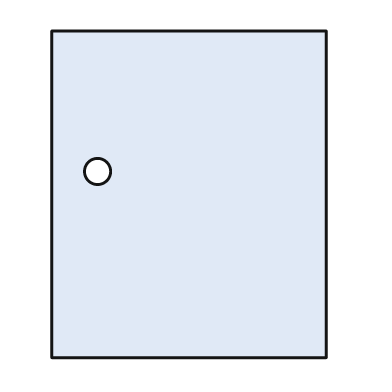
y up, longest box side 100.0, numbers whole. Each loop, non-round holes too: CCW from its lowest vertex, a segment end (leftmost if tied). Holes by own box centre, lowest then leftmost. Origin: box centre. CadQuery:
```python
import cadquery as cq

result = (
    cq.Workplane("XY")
    .moveTo(-42.0, -50.0)
    .lineTo(42.0, -50.0)
    .lineTo(42.0, 50.0)
    .lineTo(-42.0, 50.0)
    .close()
    .moveTo(-28.0, 7.0)
    .circle(4.0)
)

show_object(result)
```